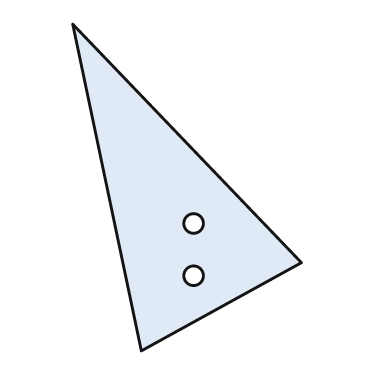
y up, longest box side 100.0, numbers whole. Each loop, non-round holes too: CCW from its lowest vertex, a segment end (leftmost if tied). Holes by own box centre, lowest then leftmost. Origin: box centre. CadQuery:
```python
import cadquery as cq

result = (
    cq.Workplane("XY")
    .moveTo(-14.0, -50.0)
    .lineTo(35.0, -23.0)
    .lineTo(-35.0, 50.0)
    .close()
    .moveTo(2.0, -27.0)
    .circle(3.0)
    .moveTo(2.0, -11.0)
    .circle(3.0)
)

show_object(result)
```